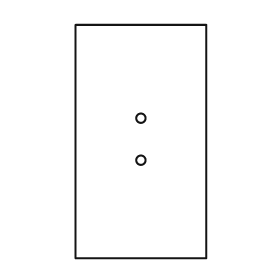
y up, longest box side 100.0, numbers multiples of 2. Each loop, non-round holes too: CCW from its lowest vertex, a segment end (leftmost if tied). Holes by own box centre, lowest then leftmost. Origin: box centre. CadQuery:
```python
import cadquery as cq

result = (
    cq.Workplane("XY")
    .moveTo(-28.0, -50.0)
    .lineTo(28.0, -50.0)
    .lineTo(28.0, 50.0)
    .lineTo(-28.0, 50.0)
    .close()
    .moveTo(0.0, -8.0)
    .circle(2.0)
    .moveTo(0.0, 10.0)
    .circle(2.0)
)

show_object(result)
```